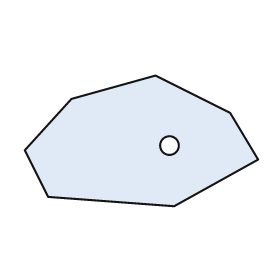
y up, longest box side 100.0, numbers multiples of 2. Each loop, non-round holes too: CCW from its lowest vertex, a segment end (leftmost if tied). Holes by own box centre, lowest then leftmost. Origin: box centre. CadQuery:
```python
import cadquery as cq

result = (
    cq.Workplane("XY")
    .moveTo(14.0, -28.0)
    .lineTo(50.0, -8.0)
    .lineTo(38.0, 12.0)
    .lineTo(6.0, 28.0)
    .lineTo(-30.0, 18.0)
    .lineTo(-50.0, -4.0)
    .lineTo(-40.0, -24.0)
    .close()
    .moveTo(12.0, -2.0)
    .circle(4.0)
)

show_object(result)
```